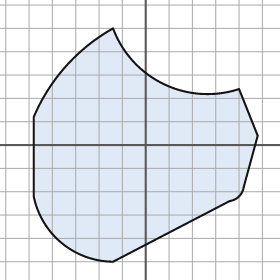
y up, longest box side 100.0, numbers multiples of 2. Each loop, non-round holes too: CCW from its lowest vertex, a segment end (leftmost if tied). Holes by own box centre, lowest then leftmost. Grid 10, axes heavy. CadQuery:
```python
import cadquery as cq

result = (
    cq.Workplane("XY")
    .moveTo(-14.0, -50.0)
    .lineTo(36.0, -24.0)
    .threePointArc((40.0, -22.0), (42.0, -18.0))
    .lineTo(48.0, 4.0)
    .lineTo(40.0, 24.0)
    .threePointArc((8.0, 26.0), (-14.0, 50.0))
    .threePointArc((-34.0, 34.0), (-48.0, 12.0))
    .lineTo(-48.0, -22.0)
    .threePointArc((-36.0, -42.0), (-14.0, -50.0))
    .close()
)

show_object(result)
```